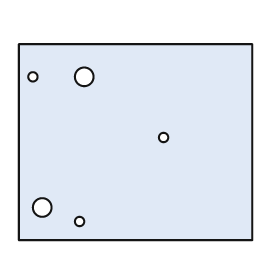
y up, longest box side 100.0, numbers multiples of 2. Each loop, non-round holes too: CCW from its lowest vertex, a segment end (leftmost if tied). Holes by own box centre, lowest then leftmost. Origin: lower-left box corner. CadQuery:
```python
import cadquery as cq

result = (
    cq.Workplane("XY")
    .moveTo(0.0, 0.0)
    .lineTo(100.0, 0.0)
    .lineTo(100.0, 84.0)
    .lineTo(0.0, 84.0)
    .close()
    .moveTo(26.0, 8.0)
    .circle(2.0)
    .moveTo(10.0, 14.0)
    .circle(4.0)
    .moveTo(62.0, 44.0)
    .circle(2.0)
    .moveTo(6.0, 70.0)
    .circle(2.0)
    .moveTo(28.0, 70.0)
    .circle(4.0)
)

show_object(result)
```